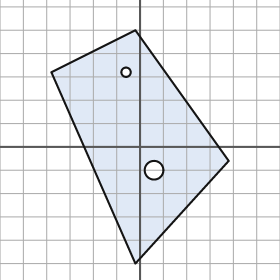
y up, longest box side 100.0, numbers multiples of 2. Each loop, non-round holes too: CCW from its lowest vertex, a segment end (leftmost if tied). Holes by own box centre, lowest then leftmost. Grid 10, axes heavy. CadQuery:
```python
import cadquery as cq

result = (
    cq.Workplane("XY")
    .moveTo(-2.0, -50.0)
    .lineTo(38.0, -6.0)
    .lineTo(-2.0, 50.0)
    .lineTo(-38.0, 32.0)
    .close()
    .moveTo(6.0, -10.0)
    .circle(4.0)
    .moveTo(-6.0, 32.0)
    .circle(2.0)
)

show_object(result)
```